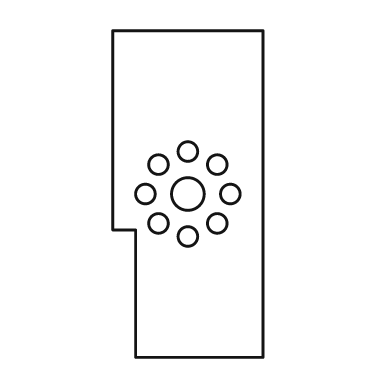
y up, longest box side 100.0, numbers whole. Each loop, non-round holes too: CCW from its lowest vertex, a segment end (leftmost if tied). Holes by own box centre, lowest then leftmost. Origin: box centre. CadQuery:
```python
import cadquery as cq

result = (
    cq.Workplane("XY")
    .moveTo(-16.0, -50.0)
    .lineTo(23.0, -50.0)
    .lineTo(23.0, 50.0)
    .lineTo(-23.0, 50.0)
    .lineTo(-23.0, -11.0)
    .lineTo(-16.0, -11.0)
    .close()
    .moveTo(0.0, -13.0)
    .circle(3.0)
    .moveTo(-9.0, -9.0)
    .circle(3.0)
    .moveTo(9.0, -9.0)
    .circle(3.0)
    .moveTo(-13.0, 0.0)
    .circle(3.0)
    .moveTo(0.0, 0.0)
    .circle(5.0)
    .moveTo(13.0, 0.0)
    .circle(3.0)
    .moveTo(-9.0, 9.0)
    .circle(3.0)
    .moveTo(9.0, 9.0)
    .circle(3.0)
    .moveTo(0.0, 13.0)
    .circle(3.0)
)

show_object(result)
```